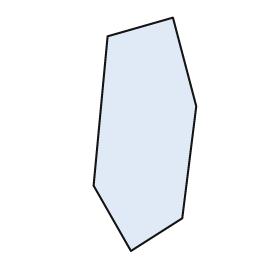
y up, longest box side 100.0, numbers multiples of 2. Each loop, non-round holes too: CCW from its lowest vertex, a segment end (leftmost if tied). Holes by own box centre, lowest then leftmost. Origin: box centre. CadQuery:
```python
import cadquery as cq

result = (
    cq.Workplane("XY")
    .moveTo(-6.0, -50.0)
    .lineTo(16.0, -36.0)
    .lineTo(22.0, 12.0)
    .lineTo(12.0, 50.0)
    .lineTo(-16.0, 42.0)
    .lineTo(-22.0, -22.0)
    .close()
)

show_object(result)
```